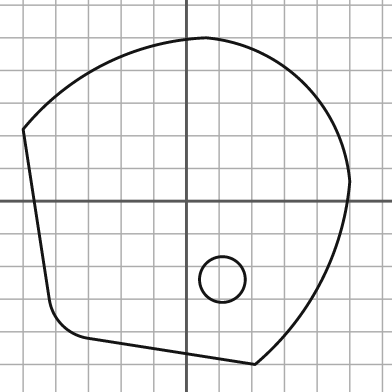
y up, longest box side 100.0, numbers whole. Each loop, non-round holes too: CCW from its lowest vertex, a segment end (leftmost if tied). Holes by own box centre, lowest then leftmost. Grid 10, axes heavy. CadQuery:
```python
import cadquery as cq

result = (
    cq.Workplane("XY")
    .moveTo(21.0, -50.0)
    .threePointArc((41.0, -25.0), (50.0, 6.0))
    .threePointArc((36.0, 36.0), (6.0, 50.0))
    .threePointArc((-25.0, 42.0), (-50.0, 22.0))
    .lineTo(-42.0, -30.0)
    .threePointArc((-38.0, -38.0), (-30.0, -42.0))
    .close()
    .moveTo(11.0, -24.0)
    .circle(7.0)
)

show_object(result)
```